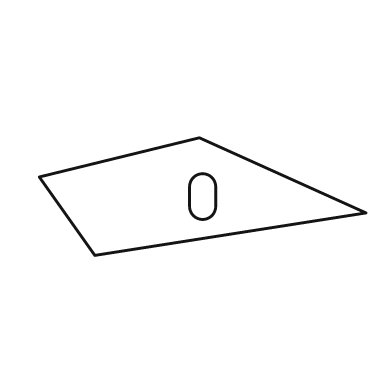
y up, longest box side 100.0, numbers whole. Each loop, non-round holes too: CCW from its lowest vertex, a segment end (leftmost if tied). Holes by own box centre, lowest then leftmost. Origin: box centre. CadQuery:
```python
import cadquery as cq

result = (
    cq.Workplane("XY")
    .moveTo(-33.0, -18.0)
    .lineTo(50.0, -5.0)
    .lineTo(-1.0, 18.0)
    .lineTo(-50.0, 6.0)
    .close()
    .moveTo(-4.0, -3.0)
    .threePointArc((0.0, -7.0), (4.0, -3.0))
    .lineTo(4.0, 3.0)
    .threePointArc((0.0, 7.0), (-4.0, 3.0))
    .close()
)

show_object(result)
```